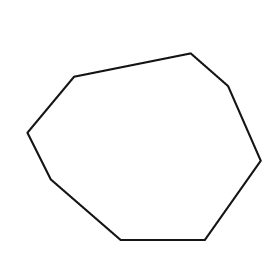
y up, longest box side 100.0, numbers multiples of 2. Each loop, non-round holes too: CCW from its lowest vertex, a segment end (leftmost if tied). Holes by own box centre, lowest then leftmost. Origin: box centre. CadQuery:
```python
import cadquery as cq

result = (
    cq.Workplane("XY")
    .moveTo(-10.0, -40.0)
    .lineTo(26.0, -40.0)
    .lineTo(50.0, -6.0)
    .lineTo(36.0, 26.0)
    .lineTo(20.0, 40.0)
    .lineTo(-30.0, 30.0)
    .lineTo(-50.0, 6.0)
    .lineTo(-40.0, -14.0)
    .close()
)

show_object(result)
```